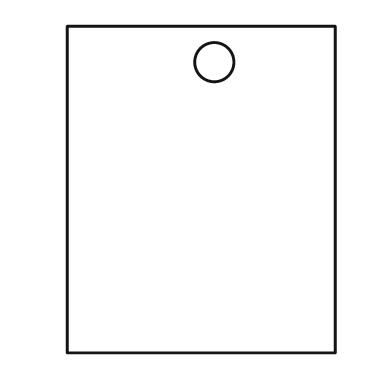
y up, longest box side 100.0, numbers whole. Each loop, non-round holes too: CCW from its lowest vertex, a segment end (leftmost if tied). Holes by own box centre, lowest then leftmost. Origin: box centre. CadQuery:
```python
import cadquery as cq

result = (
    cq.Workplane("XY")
    .moveTo(-41.0, -50.0)
    .lineTo(41.0, -50.0)
    .lineTo(41.0, 50.0)
    .lineTo(-41.0, 50.0)
    .close()
    .moveTo(4.0, 39.0)
    .circle(6.0)
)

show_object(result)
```